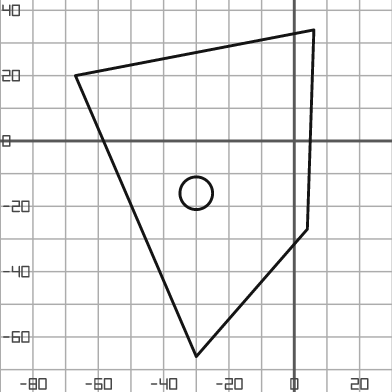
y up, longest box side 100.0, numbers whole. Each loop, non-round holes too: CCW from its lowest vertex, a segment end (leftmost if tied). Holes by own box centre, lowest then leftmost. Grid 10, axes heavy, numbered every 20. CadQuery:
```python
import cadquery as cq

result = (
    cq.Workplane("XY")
    .moveTo(-30.0, -66.0)
    .lineTo(4.0, -27.0)
    .lineTo(6.0, 34.0)
    .lineTo(-67.0, 20.0)
    .close()
    .moveTo(-30.0, -16.0)
    .circle(5.0)
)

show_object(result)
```